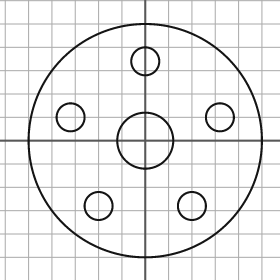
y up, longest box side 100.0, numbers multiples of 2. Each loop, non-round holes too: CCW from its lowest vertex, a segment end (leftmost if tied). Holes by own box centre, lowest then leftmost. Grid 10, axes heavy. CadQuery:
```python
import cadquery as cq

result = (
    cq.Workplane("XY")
    .moveTo(0.0, 0.0)
    .circle(50.0)
    .moveTo(-20.0, -28.0)
    .circle(6.0)
    .moveTo(20.0, -28.0)
    .circle(6.0)
    .moveTo(0.0, 0.0)
    .circle(12.0)
    .moveTo(-32.0, 10.0)
    .circle(6.0)
    .moveTo(32.0, 10.0)
    .circle(6.0)
    .moveTo(0.0, 34.0)
    .circle(6.0)
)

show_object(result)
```